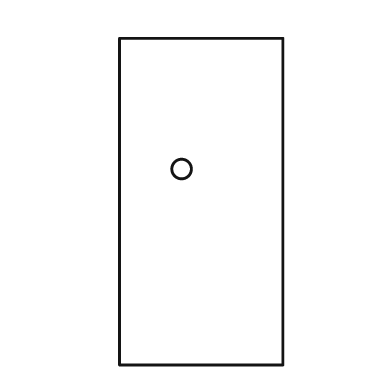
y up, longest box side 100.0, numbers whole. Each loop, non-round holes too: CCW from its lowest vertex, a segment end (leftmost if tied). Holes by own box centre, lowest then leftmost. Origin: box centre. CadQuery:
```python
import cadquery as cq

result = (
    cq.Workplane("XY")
    .moveTo(-25.0, -50.0)
    .lineTo(25.0, -50.0)
    .lineTo(25.0, 50.0)
    .lineTo(-25.0, 50.0)
    .close()
    .moveTo(-6.0, 10.0)
    .circle(3.0)
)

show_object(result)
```